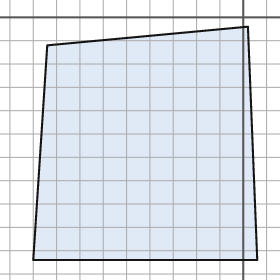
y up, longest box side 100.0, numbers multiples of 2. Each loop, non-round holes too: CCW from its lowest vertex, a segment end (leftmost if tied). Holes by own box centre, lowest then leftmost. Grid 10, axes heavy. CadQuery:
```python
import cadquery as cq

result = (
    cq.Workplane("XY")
    .moveTo(-90.0, -104.0)
    .lineTo(6.0, -104.0)
    .lineTo(2.0, -4.0)
    .lineTo(-84.0, -12.0)
    .close()
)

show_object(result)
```